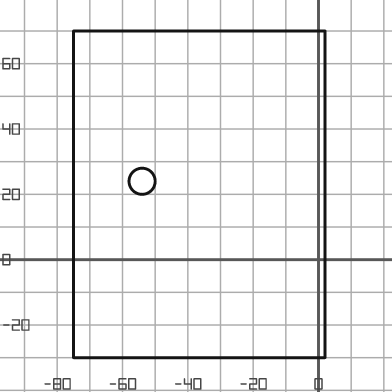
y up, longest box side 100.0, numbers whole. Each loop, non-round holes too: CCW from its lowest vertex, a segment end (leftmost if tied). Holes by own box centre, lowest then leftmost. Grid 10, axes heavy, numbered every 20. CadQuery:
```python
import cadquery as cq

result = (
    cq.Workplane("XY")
    .moveTo(-75.0, -30.0)
    .lineTo(2.0, -30.0)
    .lineTo(2.0, 70.0)
    .lineTo(-75.0, 70.0)
    .close()
    .moveTo(-54.0, 24.0)
    .circle(4.0)
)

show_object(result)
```